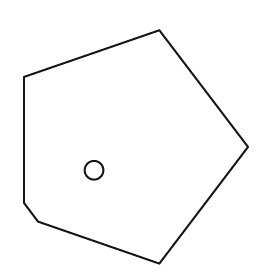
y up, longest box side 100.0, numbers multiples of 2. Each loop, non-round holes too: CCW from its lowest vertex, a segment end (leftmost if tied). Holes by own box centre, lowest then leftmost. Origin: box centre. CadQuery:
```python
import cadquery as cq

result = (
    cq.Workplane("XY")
    .moveTo(10.0, -50.0)
    .lineTo(48.0, 0.0)
    .lineTo(10.0, 50.0)
    .lineTo(-48.0, 30.0)
    .lineTo(-48.0, -24.0)
    .lineTo(-42.0, -32.0)
    .close()
    .moveTo(-18.0, -10.0)
    .circle(4.0)
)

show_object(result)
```